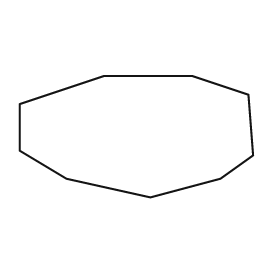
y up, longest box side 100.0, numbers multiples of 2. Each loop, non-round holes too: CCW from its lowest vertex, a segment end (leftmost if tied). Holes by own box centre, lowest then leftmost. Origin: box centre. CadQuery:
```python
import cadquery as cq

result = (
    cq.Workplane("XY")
    .moveTo(6.0, -26.0)
    .lineTo(36.0, -18.0)
    .lineTo(50.0, -8.0)
    .lineTo(48.0, 18.0)
    .lineTo(24.0, 26.0)
    .lineTo(-14.0, 26.0)
    .lineTo(-50.0, 14.0)
    .lineTo(-50.0, -6.0)
    .lineTo(-30.0, -18.0)
    .close()
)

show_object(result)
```